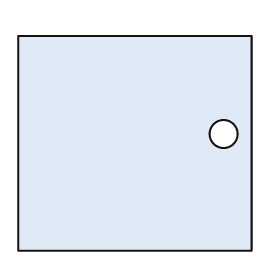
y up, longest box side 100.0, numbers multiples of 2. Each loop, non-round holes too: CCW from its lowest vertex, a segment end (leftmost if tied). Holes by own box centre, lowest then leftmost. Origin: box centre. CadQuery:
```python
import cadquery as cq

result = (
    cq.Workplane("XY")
    .moveTo(-50.0, -46.0)
    .lineTo(50.0, -46.0)
    .lineTo(50.0, 46.0)
    .lineTo(-50.0, 46.0)
    .close()
    .moveTo(38.0, 4.0)
    .circle(6.0)
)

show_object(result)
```